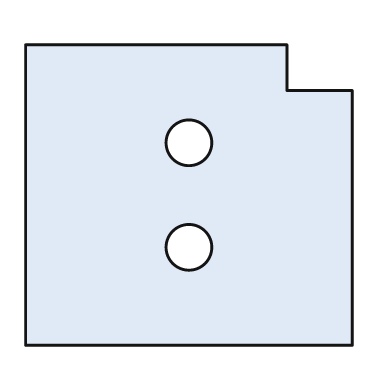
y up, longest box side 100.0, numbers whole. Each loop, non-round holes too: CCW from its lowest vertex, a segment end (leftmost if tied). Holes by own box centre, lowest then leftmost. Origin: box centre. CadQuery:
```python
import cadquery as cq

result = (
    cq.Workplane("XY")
    .moveTo(-50.0, -46.0)
    .lineTo(50.0, -46.0)
    .lineTo(50.0, 32.0)
    .lineTo(30.0, 32.0)
    .lineTo(30.0, 46.0)
    .lineTo(-50.0, 46.0)
    .close()
    .moveTo(0.0, -16.0)
    .circle(7.0)
    .moveTo(0.0, 16.0)
    .circle(7.0)
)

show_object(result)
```